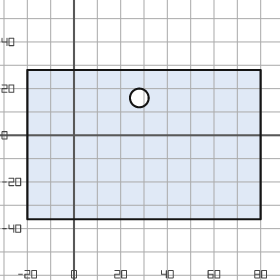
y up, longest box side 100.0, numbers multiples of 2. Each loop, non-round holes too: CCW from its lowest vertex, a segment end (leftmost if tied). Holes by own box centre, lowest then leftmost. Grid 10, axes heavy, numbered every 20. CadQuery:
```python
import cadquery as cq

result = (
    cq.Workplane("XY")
    .moveTo(-20.0, -36.0)
    .lineTo(80.0, -36.0)
    .lineTo(80.0, 28.0)
    .lineTo(-20.0, 28.0)
    .close()
    .moveTo(28.0, 16.0)
    .circle(4.0)
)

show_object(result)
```